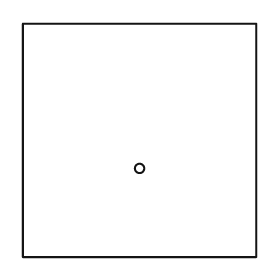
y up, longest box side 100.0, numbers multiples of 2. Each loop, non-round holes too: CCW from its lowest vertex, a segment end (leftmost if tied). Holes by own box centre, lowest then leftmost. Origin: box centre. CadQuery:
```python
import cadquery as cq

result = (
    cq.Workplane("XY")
    .moveTo(-50.0, -50.0)
    .lineTo(50.0, -50.0)
    .lineTo(50.0, 50.0)
    .lineTo(-50.0, 50.0)
    .close()
    .moveTo(0.0, -12.0)
    .circle(2.0)
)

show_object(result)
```